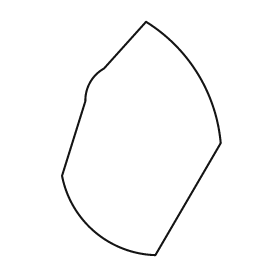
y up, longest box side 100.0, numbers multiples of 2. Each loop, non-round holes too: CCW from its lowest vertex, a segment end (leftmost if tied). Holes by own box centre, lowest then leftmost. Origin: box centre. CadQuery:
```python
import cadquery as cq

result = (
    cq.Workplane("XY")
    .moveTo(6.0, -50.0)
    .lineTo(34.0, -2.0)
    .threePointArc((24.0, 28.0), (2.0, 50.0))
    .lineTo(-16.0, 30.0)
    .threePointArc((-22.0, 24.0), (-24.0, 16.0))
    .lineTo(-34.0, -16.0)
    .threePointArc((-20.0, -40.0), (6.0, -50.0))
    .close()
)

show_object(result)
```